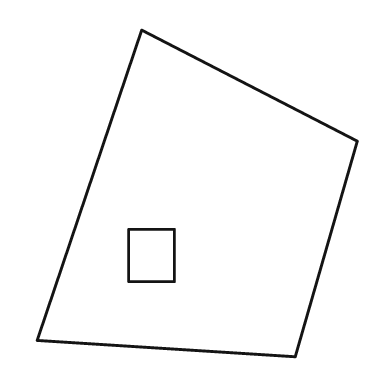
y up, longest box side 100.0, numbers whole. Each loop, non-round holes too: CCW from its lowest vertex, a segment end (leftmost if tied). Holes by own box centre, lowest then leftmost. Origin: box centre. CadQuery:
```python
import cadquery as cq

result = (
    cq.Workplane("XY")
    .moveTo(30.0, -50.0)
    .lineTo(49.0, 16.0)
    .lineTo(-17.0, 50.0)
    .lineTo(-49.0, -45.0)
    .close()
    .moveTo(-21.0, -27.0)
    .lineTo(-7.0, -27.0)
    .lineTo(-7.0, -11.0)
    .lineTo(-21.0, -11.0)
    .close()
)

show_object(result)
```